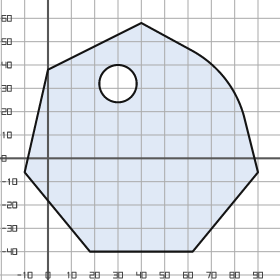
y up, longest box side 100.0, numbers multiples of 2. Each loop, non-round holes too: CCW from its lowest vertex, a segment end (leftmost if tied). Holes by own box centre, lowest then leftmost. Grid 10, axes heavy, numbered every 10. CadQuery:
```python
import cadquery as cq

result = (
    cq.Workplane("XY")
    .moveTo(18.0, -40.0)
    .lineTo(62.0, -40.0)
    .lineTo(90.0, -6.0)
    .lineTo(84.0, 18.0)
    .threePointArc((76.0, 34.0), (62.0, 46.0))
    .lineTo(40.0, 58.0)
    .lineTo(0.0, 38.0)
    .lineTo(-10.0, -6.0)
    .close()
    .moveTo(30.0, 32.0)
    .circle(8.0)
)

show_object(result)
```